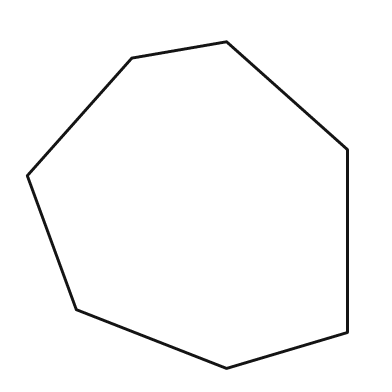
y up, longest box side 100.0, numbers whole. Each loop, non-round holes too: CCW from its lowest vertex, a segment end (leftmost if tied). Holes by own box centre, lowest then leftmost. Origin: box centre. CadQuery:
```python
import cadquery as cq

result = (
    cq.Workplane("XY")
    .moveTo(12.0, -50.0)
    .lineTo(49.0, -39.0)
    .lineTo(49.0, 17.0)
    .lineTo(12.0, 50.0)
    .lineTo(-17.0, 45.0)
    .lineTo(-49.0, 9.0)
    .lineTo(-34.0, -32.0)
    .close()
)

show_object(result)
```